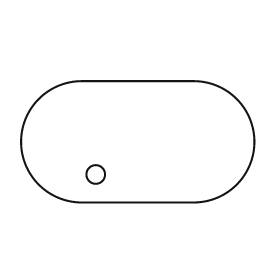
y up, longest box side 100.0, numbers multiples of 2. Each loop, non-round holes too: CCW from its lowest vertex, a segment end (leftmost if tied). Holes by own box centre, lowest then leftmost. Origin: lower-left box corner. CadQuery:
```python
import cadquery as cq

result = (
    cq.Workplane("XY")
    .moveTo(26.0, 0.0)
    .lineTo(74.0, 0.0)
    .threePointArc((100.0, 26.0), (74.0, 52.0))
    .lineTo(26.0, 52.0)
    .threePointArc((0.0, 26.0), (26.0, 0.0))
    .close()
    .moveTo(32.0, 12.0)
    .circle(4.0)
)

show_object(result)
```